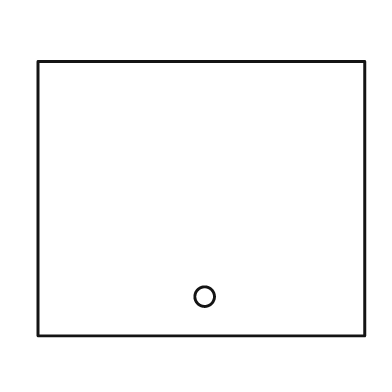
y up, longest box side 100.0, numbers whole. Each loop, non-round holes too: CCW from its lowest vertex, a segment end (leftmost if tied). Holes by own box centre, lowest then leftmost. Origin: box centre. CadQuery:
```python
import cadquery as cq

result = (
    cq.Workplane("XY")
    .moveTo(-50.0, -42.0)
    .lineTo(50.0, -42.0)
    .lineTo(50.0, 42.0)
    .lineTo(-50.0, 42.0)
    .close()
    .moveTo(1.0, -30.0)
    .circle(3.0)
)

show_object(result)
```